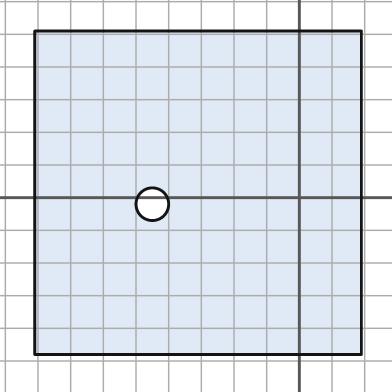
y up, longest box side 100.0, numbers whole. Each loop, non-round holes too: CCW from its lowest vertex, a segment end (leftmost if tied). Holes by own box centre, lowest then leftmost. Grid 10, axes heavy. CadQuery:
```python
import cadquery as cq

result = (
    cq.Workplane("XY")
    .moveTo(-81.0, -48.0)
    .lineTo(19.0, -48.0)
    .lineTo(19.0, 51.0)
    .lineTo(-81.0, 51.0)
    .close()
    .moveTo(-45.0, -2.0)
    .circle(5.0)
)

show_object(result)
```